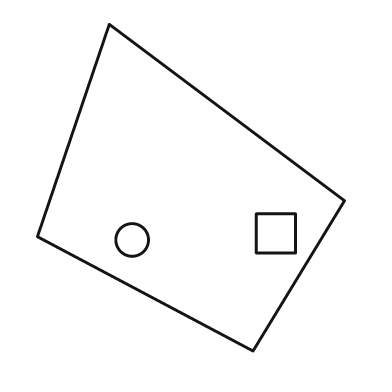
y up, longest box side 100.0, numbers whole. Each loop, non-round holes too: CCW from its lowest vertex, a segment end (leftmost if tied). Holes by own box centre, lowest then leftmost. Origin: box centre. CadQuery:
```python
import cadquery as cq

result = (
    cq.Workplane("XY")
    .moveTo(19.0, -50.0)
    .lineTo(47.0, -4.0)
    .lineTo(-25.0, 50.0)
    .lineTo(-47.0, -15.0)
    .close()
    .moveTo(-18.0, -16.0)
    .circle(5.0)
    .moveTo(20.0, -20.0)
    .lineTo(32.0, -20.0)
    .lineTo(32.0, -8.0)
    .lineTo(20.0, -8.0)
    .close()
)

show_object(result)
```